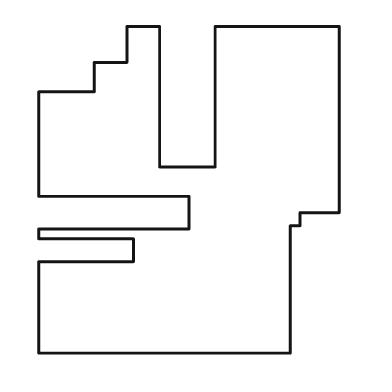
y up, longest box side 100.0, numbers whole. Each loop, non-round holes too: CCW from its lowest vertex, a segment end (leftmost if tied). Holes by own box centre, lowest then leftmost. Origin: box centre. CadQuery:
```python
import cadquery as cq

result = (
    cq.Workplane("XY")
    .moveTo(-46.0, -50.0)
    .lineTo(31.0, -50.0)
    .lineTo(31.0, -11.0)
    .lineTo(34.0, -11.0)
    .lineTo(34.0, -7.0)
    .lineTo(46.0, -7.0)
    .lineTo(46.0, 50.0)
    .lineTo(8.0, 50.0)
    .lineTo(8.0, 7.0)
    .lineTo(-9.0, 7.0)
    .lineTo(-9.0, 50.0)
    .lineTo(-19.0, 50.0)
    .lineTo(-19.0, 39.0)
    .lineTo(-29.0, 39.0)
    .lineTo(-29.0, 30.0)
    .lineTo(-46.0, 30.0)
    .lineTo(-46.0, -2.0)
    .lineTo(0.0, -2.0)
    .lineTo(0.0, -12.0)
    .lineTo(-46.0, -12.0)
    .lineTo(-46.0, -15.0)
    .lineTo(-17.0, -15.0)
    .lineTo(-17.0, -22.0)
    .lineTo(-46.0, -22.0)
    .close()
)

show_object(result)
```